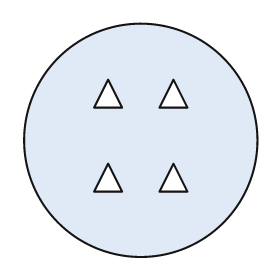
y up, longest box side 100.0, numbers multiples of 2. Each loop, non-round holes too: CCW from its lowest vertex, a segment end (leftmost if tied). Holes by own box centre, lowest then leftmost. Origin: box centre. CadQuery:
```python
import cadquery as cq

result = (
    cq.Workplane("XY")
    .moveTo(0.0, 0.0)
    .circle(50.0)
    .moveTo(-20.0, -22.0)
    .lineTo(-8.0, -22.0)
    .lineTo(-14.0, -10.0)
    .close()
    .moveTo(8.0, -22.0)
    .lineTo(20.0, -22.0)
    .lineTo(14.0, -10.0)
    .close()
    .moveTo(-20.0, 14.0)
    .lineTo(-8.0, 14.0)
    .lineTo(-14.0, 26.0)
    .close()
    .moveTo(8.0, 14.0)
    .lineTo(20.0, 14.0)
    .lineTo(14.0, 26.0)
    .close()
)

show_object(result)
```